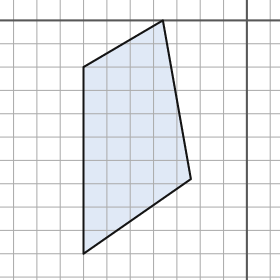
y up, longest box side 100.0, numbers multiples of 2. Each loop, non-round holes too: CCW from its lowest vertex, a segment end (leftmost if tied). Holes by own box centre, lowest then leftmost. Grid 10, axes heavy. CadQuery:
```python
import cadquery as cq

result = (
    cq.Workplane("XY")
    .moveTo(-70.0, -100.0)
    .lineTo(-24.0, -68.0)
    .lineTo(-36.0, 0.0)
    .lineTo(-70.0, -20.0)
    .close()
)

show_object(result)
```